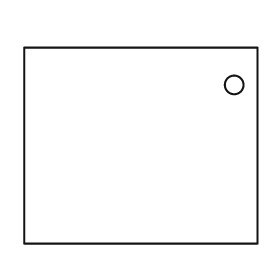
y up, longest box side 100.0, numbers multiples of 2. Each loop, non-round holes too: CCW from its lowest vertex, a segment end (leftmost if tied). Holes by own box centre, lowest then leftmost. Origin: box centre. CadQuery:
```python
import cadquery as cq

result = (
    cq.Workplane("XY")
    .moveTo(-50.0, -42.0)
    .lineTo(50.0, -42.0)
    .lineTo(50.0, 42.0)
    .lineTo(-50.0, 42.0)
    .close()
    .moveTo(40.0, 26.0)
    .circle(4.0)
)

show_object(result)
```